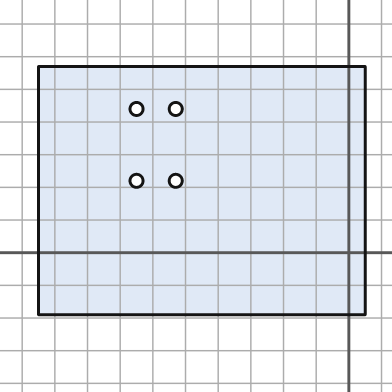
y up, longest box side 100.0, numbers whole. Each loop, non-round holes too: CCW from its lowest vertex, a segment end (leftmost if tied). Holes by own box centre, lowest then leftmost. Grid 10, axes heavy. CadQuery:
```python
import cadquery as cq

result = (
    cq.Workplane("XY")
    .moveTo(-95.0, -19.0)
    .lineTo(5.0, -19.0)
    .lineTo(5.0, 57.0)
    .lineTo(-95.0, 57.0)
    .close()
    .moveTo(-65.0, 22.0)
    .circle(2.0)
    .moveTo(-53.0, 22.0)
    .circle(2.0)
    .moveTo(-65.0, 44.0)
    .circle(2.0)
    .moveTo(-53.0, 44.0)
    .circle(2.0)
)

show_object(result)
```